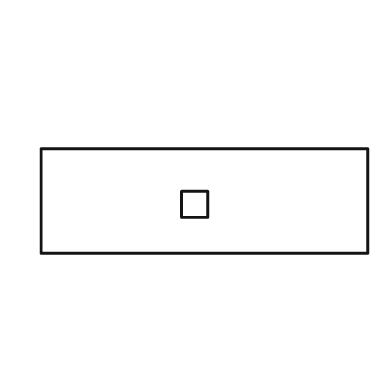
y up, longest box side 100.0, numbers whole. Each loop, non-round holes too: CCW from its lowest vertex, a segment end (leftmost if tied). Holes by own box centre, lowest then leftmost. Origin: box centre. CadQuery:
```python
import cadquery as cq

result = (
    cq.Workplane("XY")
    .moveTo(-50.0, -16.0)
    .lineTo(50.0, -16.0)
    .lineTo(50.0, 16.0)
    .lineTo(-50.0, 16.0)
    .close()
    .moveTo(-7.0, -5.0)
    .lineTo(1.0, -5.0)
    .lineTo(1.0, 3.0)
    .lineTo(-7.0, 3.0)
    .close()
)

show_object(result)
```